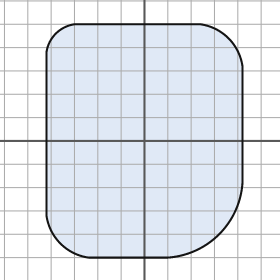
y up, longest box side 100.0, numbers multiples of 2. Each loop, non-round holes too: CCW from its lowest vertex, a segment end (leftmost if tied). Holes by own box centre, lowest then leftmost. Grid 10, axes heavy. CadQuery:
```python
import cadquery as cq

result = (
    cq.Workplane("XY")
    .moveTo(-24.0, -50.0)
    .lineTo(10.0, -50.0)
    .threePointArc((32.0, -40.0), (42.0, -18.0))
    .lineTo(42.0, 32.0)
    .threePointArc((36.0, 44.0), (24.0, 50.0))
    .lineTo(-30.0, 50.0)
    .threePointArc((-38.0, 46.0), (-42.0, 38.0))
    .lineTo(-42.0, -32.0)
    .threePointArc((-36.0, -44.0), (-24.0, -50.0))
    .close()
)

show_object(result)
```